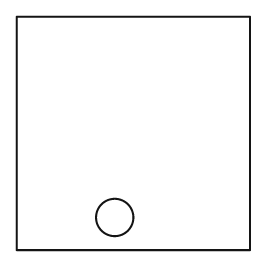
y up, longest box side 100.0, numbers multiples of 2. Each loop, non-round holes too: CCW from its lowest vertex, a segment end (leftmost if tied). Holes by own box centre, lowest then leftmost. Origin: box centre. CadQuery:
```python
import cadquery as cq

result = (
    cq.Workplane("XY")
    .moveTo(-50.0, -50.0)
    .lineTo(50.0, -50.0)
    .lineTo(50.0, 50.0)
    .lineTo(-50.0, 50.0)
    .close()
    .moveTo(-8.0, -36.0)
    .circle(8.0)
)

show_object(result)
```